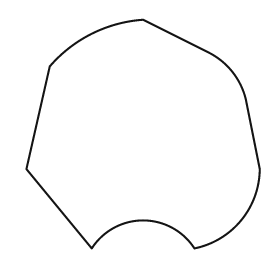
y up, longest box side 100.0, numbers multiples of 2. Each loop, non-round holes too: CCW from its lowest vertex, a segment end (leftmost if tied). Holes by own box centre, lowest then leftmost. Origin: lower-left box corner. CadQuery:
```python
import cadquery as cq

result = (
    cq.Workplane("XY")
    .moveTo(28.0, 0.0)
    .threePointArc((50.0, 12.0), (72.0, 0.0))
    .threePointArc((92.0, 12.0), (100.0, 34.0))
    .lineTo(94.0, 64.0)
    .threePointArc((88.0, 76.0), (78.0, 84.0))
    .lineTo(50.0, 98.0)
    .threePointArc((28.0, 92.0), (10.0, 78.0))
    .lineTo(0.0, 34.0)
    .close()
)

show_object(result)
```